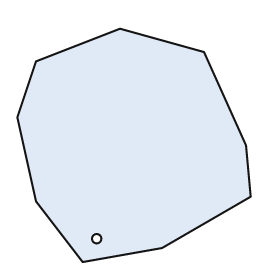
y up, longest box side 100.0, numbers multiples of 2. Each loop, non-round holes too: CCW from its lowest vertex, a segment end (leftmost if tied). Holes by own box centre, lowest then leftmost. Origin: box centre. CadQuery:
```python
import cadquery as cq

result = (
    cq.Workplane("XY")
    .moveTo(-22.0, -50.0)
    .lineTo(12.0, -44.0)
    .lineTo(50.0, -22.0)
    .lineTo(48.0, 0.0)
    .lineTo(30.0, 40.0)
    .lineTo(-6.0, 50.0)
    .lineTo(-42.0, 36.0)
    .lineTo(-50.0, 12.0)
    .lineTo(-42.0, -24.0)
    .close()
    .moveTo(-16.0, -40.0)
    .circle(2.0)
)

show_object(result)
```